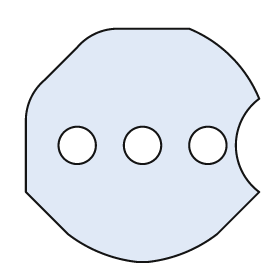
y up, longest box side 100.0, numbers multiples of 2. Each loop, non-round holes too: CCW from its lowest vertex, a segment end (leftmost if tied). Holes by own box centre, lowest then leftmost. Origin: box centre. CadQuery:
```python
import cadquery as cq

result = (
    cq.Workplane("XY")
    .moveTo(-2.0, -50.0)
    .lineTo(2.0, -50.0)
    .threePointArc((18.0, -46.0), (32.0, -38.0))
    .lineTo(50.0, -20.0)
    .threePointArc((40.0, 0.0), (50.0, 20.0))
    .threePointArc((38.0, 38.0), (20.0, 50.0))
    .lineTo(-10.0, 50.0)
    .threePointArc((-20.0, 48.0), (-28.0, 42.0))
    .lineTo(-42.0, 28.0)
    .threePointArc((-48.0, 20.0), (-50.0, 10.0))
    .lineTo(-50.0, -20.0)
    .lineTo(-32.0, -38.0)
    .threePointArc((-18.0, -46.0), (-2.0, -50.0))
    .close()
    .moveTo(-28.0, 0.0)
    .circle(8.0)
    .moveTo(0.0, 0.0)
    .circle(8.0)
    .moveTo(28.0, 0.0)
    .circle(8.0)
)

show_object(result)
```